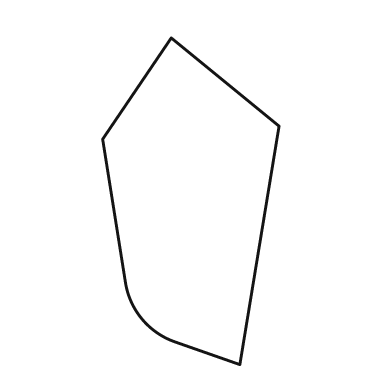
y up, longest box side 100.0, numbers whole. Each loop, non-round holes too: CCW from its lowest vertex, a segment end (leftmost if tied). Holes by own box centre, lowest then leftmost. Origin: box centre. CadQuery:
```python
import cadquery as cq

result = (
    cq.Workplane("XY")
    .moveTo(15.0, -50.0)
    .lineTo(27.0, 23.0)
    .lineTo(-6.0, 50.0)
    .lineTo(-27.0, 19.0)
    .lineTo(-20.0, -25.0)
    .threePointArc((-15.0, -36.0), (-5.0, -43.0))
    .close()
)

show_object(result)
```